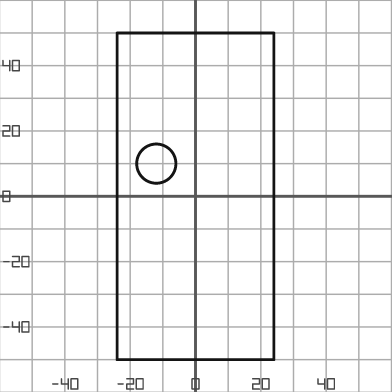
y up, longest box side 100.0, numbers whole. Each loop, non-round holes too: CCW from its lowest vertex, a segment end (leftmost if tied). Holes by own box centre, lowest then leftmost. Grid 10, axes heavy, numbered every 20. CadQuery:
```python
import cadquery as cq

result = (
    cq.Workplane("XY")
    .moveTo(-24.0, -50.0)
    .lineTo(24.0, -50.0)
    .lineTo(24.0, 50.0)
    .lineTo(-24.0, 50.0)
    .close()
    .moveTo(-12.0, 10.0)
    .circle(6.0)
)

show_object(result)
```